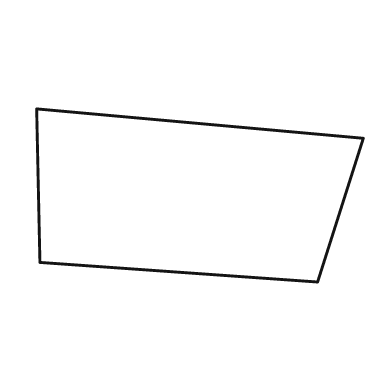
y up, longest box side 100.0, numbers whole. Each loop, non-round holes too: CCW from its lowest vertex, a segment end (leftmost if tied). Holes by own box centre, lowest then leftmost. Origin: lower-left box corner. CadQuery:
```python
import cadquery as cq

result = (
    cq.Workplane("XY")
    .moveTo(86.0, 0.0)
    .lineTo(100.0, 44.0)
    .lineTo(0.0, 53.0)
    .lineTo(1.0, 6.0)
    .close()
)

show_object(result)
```